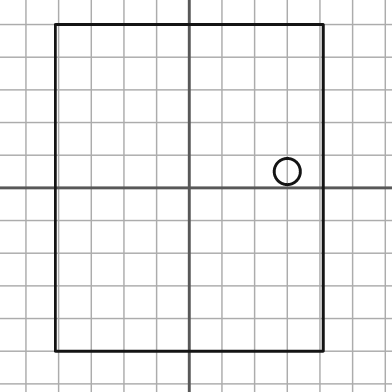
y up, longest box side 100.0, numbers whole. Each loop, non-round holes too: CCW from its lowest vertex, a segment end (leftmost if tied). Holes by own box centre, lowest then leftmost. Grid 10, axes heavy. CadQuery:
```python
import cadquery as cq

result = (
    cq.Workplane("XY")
    .moveTo(-41.0, -50.0)
    .lineTo(41.0, -50.0)
    .lineTo(41.0, 50.0)
    .lineTo(-41.0, 50.0)
    .close()
    .moveTo(30.0, 5.0)
    .circle(4.0)
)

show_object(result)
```